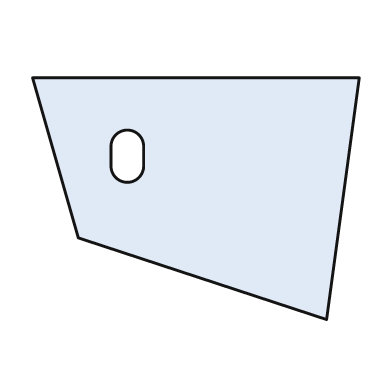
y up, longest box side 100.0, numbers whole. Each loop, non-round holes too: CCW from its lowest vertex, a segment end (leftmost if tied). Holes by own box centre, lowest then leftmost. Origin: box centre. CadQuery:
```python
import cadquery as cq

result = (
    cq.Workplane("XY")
    .moveTo(40.0, -37.0)
    .lineTo(50.0, 37.0)
    .lineTo(-50.0, 37.0)
    .lineTo(-36.0, -12.0)
    .close()
    .moveTo(-26.0, 10.0)
    .threePointArc((-21.0, 5.0), (-16.0, 10.0))
    .lineTo(-16.0, 16.0)
    .threePointArc((-21.0, 21.0), (-26.0, 16.0))
    .close()
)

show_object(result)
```